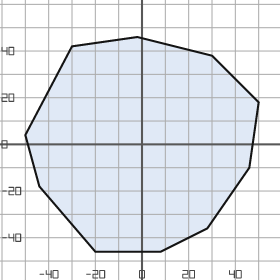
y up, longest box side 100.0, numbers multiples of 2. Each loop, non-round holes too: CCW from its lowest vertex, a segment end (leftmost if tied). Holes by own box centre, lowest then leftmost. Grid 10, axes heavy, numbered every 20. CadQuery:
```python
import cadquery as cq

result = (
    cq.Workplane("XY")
    .moveTo(-20.0, -46.0)
    .lineTo(8.0, -46.0)
    .lineTo(28.0, -36.0)
    .lineTo(46.0, -10.0)
    .lineTo(50.0, 18.0)
    .lineTo(30.0, 38.0)
    .lineTo(-2.0, 46.0)
    .lineTo(-30.0, 42.0)
    .lineTo(-50.0, 4.0)
    .lineTo(-44.0, -18.0)
    .close()
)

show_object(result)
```